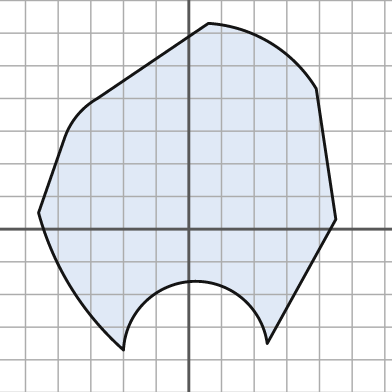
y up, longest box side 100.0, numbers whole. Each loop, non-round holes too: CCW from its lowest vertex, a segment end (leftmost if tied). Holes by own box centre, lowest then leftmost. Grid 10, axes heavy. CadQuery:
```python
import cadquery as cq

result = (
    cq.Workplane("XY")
    .moveTo(-20.0, -37.0)
    .threePointArc((1.0, -16.0), (24.0, -35.0))
    .lineTo(45.0, 3.0)
    .lineTo(39.0, 43.0)
    .threePointArc((25.0, 57.0), (6.0, 63.0))
    .lineTo(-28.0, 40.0)
    .threePointArc((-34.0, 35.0), (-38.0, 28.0))
    .lineTo(-46.0, 5.0)
    .threePointArc((-36.0, -18.0), (-20.0, -37.0))
    .close()
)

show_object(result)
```